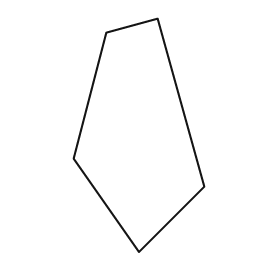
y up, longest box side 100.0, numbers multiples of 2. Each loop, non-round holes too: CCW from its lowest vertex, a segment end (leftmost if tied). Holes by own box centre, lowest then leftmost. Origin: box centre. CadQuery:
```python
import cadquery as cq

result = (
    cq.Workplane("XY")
    .moveTo(0.0, -50.0)
    .lineTo(28.0, -22.0)
    .lineTo(8.0, 50.0)
    .lineTo(-14.0, 44.0)
    .lineTo(-28.0, -10.0)
    .close()
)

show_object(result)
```